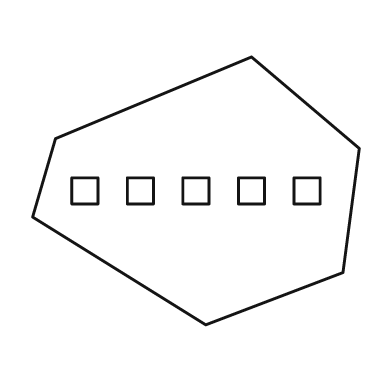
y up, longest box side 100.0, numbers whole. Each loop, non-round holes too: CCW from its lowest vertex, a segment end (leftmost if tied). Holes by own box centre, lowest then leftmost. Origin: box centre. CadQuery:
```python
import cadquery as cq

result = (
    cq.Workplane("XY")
    .moveTo(3.0, -41.0)
    .lineTo(45.0, -25.0)
    .lineTo(50.0, 13.0)
    .lineTo(17.0, 41.0)
    .lineTo(-43.0, 16.0)
    .lineTo(-50.0, -8.0)
    .close()
    .moveTo(-38.0, -4.0)
    .lineTo(-30.0, -4.0)
    .lineTo(-30.0, 4.0)
    .lineTo(-38.0, 4.0)
    .close()
    .moveTo(-21.0, -4.0)
    .lineTo(-13.0, -4.0)
    .lineTo(-13.0, 4.0)
    .lineTo(-21.0, 4.0)
    .close()
    .moveTo(-4.0, -4.0)
    .lineTo(4.0, -4.0)
    .lineTo(4.0, 4.0)
    .lineTo(-4.0, 4.0)
    .close()
    .moveTo(13.0, -4.0)
    .lineTo(21.0, -4.0)
    .lineTo(21.0, 4.0)
    .lineTo(13.0, 4.0)
    .close()
    .moveTo(30.0, -4.0)
    .lineTo(38.0, -4.0)
    .lineTo(38.0, 4.0)
    .lineTo(30.0, 4.0)
    .close()
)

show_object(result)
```